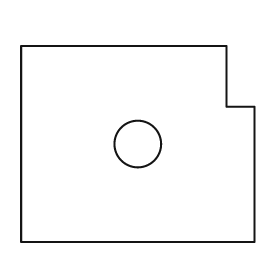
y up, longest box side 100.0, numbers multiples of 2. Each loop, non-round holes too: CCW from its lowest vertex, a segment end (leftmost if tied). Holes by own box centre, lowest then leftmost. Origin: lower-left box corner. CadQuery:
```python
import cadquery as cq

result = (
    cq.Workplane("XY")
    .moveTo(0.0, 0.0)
    .lineTo(100.0, 0.0)
    .lineTo(100.0, 58.0)
    .lineTo(88.0, 58.0)
    .lineTo(88.0, 84.0)
    .lineTo(0.0, 84.0)
    .close()
    .moveTo(50.0, 42.0)
    .circle(10.0)
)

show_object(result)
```